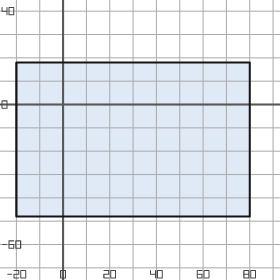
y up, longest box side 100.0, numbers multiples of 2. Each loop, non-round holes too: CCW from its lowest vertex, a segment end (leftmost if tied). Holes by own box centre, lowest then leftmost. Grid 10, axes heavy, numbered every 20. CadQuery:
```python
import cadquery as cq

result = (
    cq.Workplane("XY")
    .moveTo(-20.0, -48.0)
    .lineTo(80.0, -48.0)
    .lineTo(80.0, 18.0)
    .lineTo(-20.0, 18.0)
    .close()
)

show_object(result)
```